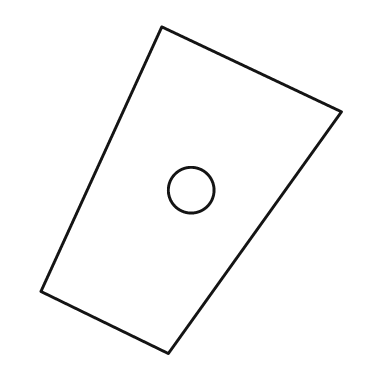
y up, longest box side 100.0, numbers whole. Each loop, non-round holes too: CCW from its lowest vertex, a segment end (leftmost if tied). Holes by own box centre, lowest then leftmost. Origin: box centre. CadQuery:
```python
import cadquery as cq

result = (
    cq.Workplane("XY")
    .moveTo(-7.0, -50.0)
    .lineTo(46.0, 24.0)
    .lineTo(-9.0, 50.0)
    .lineTo(-46.0, -31.0)
    .close()
    .moveTo(0.0, 0.0)
    .circle(7.0)
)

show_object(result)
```